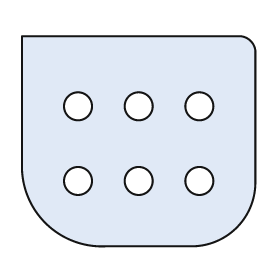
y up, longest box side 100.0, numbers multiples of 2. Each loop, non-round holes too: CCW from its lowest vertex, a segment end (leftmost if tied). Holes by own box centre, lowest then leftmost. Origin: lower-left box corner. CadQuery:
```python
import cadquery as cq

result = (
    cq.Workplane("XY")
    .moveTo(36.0, 0.0)
    .lineTo(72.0, 0.0)
    .threePointArc((92.0, 8.0), (100.0, 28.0))
    .lineTo(100.0, 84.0)
    .threePointArc((98.0, 88.0), (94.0, 90.0))
    .lineTo(0.0, 90.0)
    .lineTo(0.0, 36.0)
    .threePointArc((10.0, 10.0), (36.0, 0.0))
    .close()
    .moveTo(24.0, 28.0)
    .circle(6.0)
    .moveTo(50.0, 28.0)
    .circle(6.0)
    .moveTo(76.0, 28.0)
    .circle(6.0)
    .moveTo(24.0, 60.0)
    .circle(6.0)
    .moveTo(50.0, 60.0)
    .circle(6.0)
    .moveTo(76.0, 60.0)
    .circle(6.0)
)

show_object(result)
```